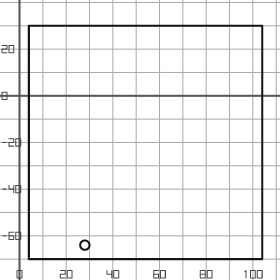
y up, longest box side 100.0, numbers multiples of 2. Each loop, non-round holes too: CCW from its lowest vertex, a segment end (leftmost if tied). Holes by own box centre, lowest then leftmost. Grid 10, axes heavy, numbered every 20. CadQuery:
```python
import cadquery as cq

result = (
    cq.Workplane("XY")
    .moveTo(4.0, -70.0)
    .lineTo(104.0, -70.0)
    .lineTo(104.0, 30.0)
    .lineTo(4.0, 30.0)
    .close()
    .moveTo(28.0, -64.0)
    .circle(2.0)
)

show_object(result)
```